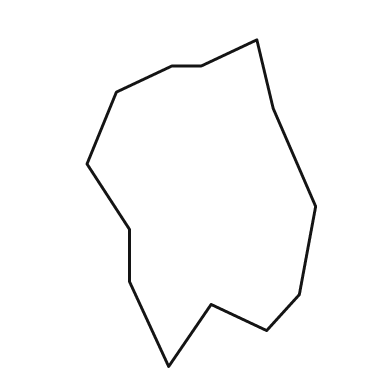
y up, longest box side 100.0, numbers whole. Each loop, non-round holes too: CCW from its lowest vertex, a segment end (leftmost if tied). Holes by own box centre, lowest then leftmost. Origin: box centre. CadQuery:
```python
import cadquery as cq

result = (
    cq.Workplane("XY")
    .moveTo(-10.0, -50.0)
    .lineTo(3.0, -31.0)
    .lineTo(20.0, -39.0)
    .lineTo(30.0, -28.0)
    .lineTo(35.0, -1.0)
    .lineTo(22.0, 29.0)
    .lineTo(17.0, 50.0)
    .lineTo(0.0, 42.0)
    .lineTo(-9.0, 42.0)
    .lineTo(-26.0, 34.0)
    .lineTo(-35.0, 12.0)
    .lineTo(-22.0, -8.0)
    .lineTo(-22.0, -24.0)
    .close()
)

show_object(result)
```